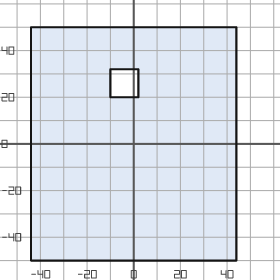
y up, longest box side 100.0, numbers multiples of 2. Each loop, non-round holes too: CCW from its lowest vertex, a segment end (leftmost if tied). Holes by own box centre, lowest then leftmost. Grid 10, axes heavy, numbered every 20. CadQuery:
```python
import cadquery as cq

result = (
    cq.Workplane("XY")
    .moveTo(-44.0, -50.0)
    .lineTo(44.0, -50.0)
    .lineTo(44.0, 50.0)
    .lineTo(-44.0, 50.0)
    .close()
    .moveTo(-10.0, 20.0)
    .lineTo(2.0, 20.0)
    .lineTo(2.0, 32.0)
    .lineTo(-10.0, 32.0)
    .close()
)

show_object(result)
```